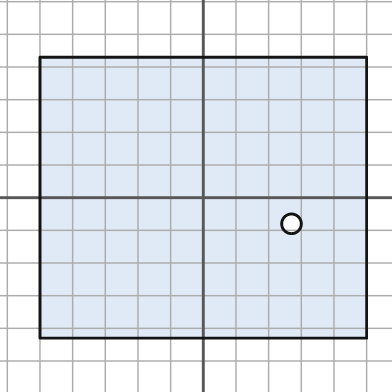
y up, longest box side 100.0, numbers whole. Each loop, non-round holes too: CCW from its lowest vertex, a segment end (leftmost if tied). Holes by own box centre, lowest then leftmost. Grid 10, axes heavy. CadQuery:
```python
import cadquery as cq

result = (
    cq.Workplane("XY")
    .moveTo(-50.0, -43.0)
    .lineTo(50.0, -43.0)
    .lineTo(50.0, 43.0)
    .lineTo(-50.0, 43.0)
    .close()
    .moveTo(27.0, -8.0)
    .circle(3.0)
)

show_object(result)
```